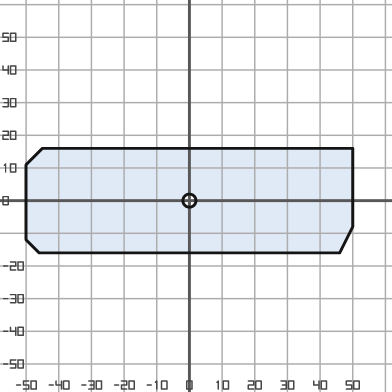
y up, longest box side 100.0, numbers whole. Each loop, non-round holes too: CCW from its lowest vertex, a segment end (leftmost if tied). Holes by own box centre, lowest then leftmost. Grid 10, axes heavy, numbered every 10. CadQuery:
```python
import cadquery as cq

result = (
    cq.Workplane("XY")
    .moveTo(-46.0, -16.0)
    .lineTo(46.0, -16.0)
    .lineTo(50.0, -8.0)
    .lineTo(50.0, 16.0)
    .lineTo(-45.0, 16.0)
    .lineTo(-50.0, 11.0)
    .lineTo(-50.0, -12.0)
    .close()
    .moveTo(0.0, 0.0)
    .circle(2.0)
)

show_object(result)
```